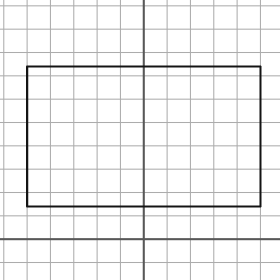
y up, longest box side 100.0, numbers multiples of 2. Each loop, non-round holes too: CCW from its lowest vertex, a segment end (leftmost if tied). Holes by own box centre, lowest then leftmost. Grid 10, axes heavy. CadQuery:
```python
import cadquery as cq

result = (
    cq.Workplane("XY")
    .moveTo(-50.0, 14.0)
    .lineTo(50.0, 14.0)
    .lineTo(50.0, 74.0)
    .lineTo(-50.0, 74.0)
    .close()
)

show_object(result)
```